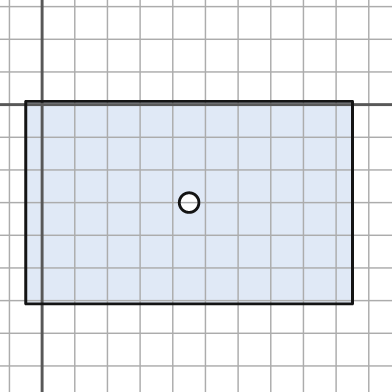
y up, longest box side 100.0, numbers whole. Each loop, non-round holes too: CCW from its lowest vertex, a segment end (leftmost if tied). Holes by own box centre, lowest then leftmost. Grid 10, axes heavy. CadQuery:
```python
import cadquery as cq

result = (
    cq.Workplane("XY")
    .moveTo(-5.0, -61.0)
    .lineTo(95.0, -61.0)
    .lineTo(95.0, 1.0)
    .lineTo(-5.0, 1.0)
    .close()
    .moveTo(45.0, -30.0)
    .circle(3.0)
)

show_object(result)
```